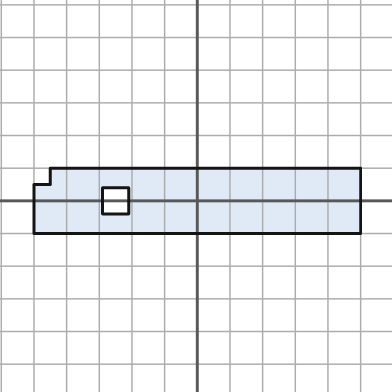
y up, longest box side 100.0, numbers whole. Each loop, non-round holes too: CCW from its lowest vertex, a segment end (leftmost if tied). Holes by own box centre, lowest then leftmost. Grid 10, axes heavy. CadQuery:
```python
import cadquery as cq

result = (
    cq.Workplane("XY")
    .moveTo(-50.0, -10.0)
    .lineTo(50.0, -10.0)
    .lineTo(50.0, 10.0)
    .lineTo(-45.0, 10.0)
    .lineTo(-45.0, 5.0)
    .lineTo(-50.0, 5.0)
    .close()
    .moveTo(-29.0, -4.0)
    .lineTo(-21.0, -4.0)
    .lineTo(-21.0, 4.0)
    .lineTo(-29.0, 4.0)
    .close()
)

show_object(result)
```